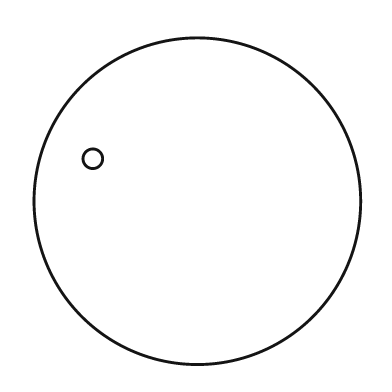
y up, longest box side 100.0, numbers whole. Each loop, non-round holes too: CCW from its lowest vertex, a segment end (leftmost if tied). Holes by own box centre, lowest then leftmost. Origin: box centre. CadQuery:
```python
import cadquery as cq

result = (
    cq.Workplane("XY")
    .moveTo(0.0, 0.0)
    .circle(50.0)
    .moveTo(-32.0, 13.0)
    .circle(3.0)
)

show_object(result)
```